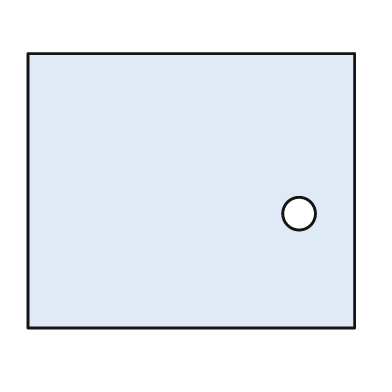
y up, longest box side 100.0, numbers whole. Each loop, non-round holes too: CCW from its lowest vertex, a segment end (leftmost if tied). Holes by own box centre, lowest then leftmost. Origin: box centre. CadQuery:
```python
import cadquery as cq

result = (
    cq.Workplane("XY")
    .moveTo(-50.0, -42.0)
    .lineTo(50.0, -42.0)
    .lineTo(50.0, 42.0)
    .lineTo(-50.0, 42.0)
    .close()
    .moveTo(33.0, -7.0)
    .circle(5.0)
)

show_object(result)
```